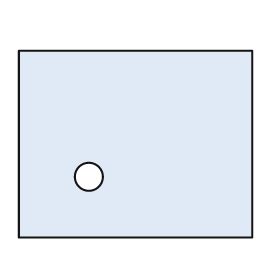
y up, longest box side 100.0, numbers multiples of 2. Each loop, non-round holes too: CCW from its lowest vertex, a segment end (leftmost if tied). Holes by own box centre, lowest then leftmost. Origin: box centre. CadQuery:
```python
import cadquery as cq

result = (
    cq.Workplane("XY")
    .moveTo(-50.0, -40.0)
    .lineTo(50.0, -40.0)
    .lineTo(50.0, 40.0)
    .lineTo(-50.0, 40.0)
    .close()
    .moveTo(-20.0, -14.0)
    .circle(6.0)
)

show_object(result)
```